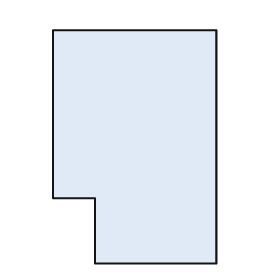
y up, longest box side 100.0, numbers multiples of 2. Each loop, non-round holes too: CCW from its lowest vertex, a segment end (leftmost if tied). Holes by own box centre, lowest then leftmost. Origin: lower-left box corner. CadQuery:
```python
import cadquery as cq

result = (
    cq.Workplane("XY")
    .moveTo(18.0, 0.0)
    .lineTo(70.0, 0.0)
    .lineTo(70.0, 100.0)
    .lineTo(0.0, 100.0)
    .lineTo(0.0, 28.0)
    .lineTo(18.0, 28.0)
    .close()
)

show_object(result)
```